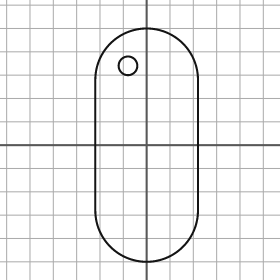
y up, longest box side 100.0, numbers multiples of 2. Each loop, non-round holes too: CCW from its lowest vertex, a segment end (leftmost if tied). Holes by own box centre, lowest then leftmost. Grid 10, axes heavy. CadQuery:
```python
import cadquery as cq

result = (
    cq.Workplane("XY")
    .moveTo(-22.0, -28.0)
    .threePointArc((0.0, -50.0), (22.0, -28.0))
    .lineTo(22.0, 28.0)
    .threePointArc((0.0, 50.0), (-22.0, 28.0))
    .close()
    .moveTo(-8.0, 34.0)
    .circle(4.0)
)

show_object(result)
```